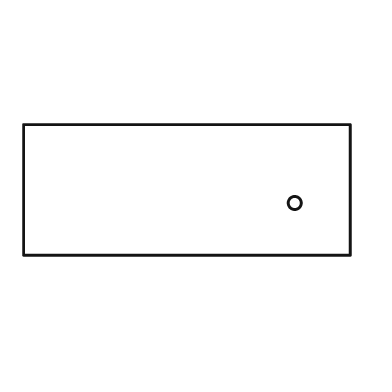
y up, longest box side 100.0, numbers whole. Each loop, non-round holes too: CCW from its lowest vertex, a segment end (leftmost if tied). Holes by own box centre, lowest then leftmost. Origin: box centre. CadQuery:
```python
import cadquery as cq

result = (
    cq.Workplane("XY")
    .moveTo(-50.0, -20.0)
    .lineTo(50.0, -20.0)
    .lineTo(50.0, 20.0)
    .lineTo(-50.0, 20.0)
    .close()
    .moveTo(33.0, -4.0)
    .circle(2.0)
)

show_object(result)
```